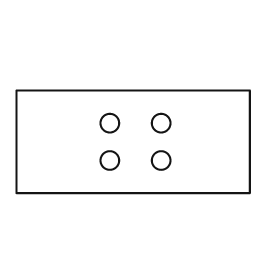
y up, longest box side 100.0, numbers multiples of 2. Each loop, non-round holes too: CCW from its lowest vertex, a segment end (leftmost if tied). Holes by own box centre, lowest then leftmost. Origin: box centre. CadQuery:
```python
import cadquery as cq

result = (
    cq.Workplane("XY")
    .moveTo(-50.0, -22.0)
    .lineTo(50.0, -22.0)
    .lineTo(50.0, 22.0)
    .lineTo(-50.0, 22.0)
    .close()
    .moveTo(-10.0, -8.0)
    .circle(4.0)
    .moveTo(12.0, -8.0)
    .circle(4.0)
    .moveTo(-10.0, 8.0)
    .circle(4.0)
    .moveTo(12.0, 8.0)
    .circle(4.0)
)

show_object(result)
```